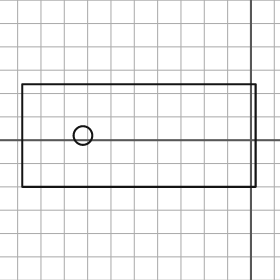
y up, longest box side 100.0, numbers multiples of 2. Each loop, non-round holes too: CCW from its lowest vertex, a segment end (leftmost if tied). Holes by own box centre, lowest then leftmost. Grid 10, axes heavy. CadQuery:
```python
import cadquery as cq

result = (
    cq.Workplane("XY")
    .moveTo(-98.0, -20.0)
    .lineTo(2.0, -20.0)
    .lineTo(2.0, 24.0)
    .lineTo(-98.0, 24.0)
    .close()
    .moveTo(-72.0, 2.0)
    .circle(4.0)
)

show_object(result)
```